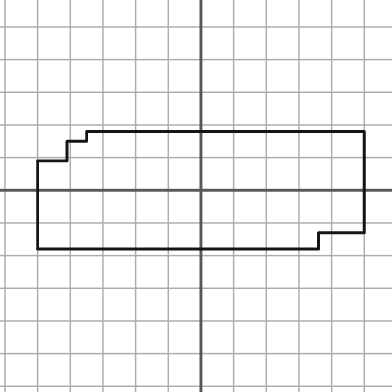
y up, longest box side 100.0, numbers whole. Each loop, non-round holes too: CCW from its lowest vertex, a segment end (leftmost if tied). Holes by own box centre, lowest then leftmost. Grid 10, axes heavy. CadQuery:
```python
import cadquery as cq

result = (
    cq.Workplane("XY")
    .moveTo(-50.0, -18.0)
    .lineTo(36.0, -18.0)
    .lineTo(36.0, -13.0)
    .lineTo(50.0, -13.0)
    .lineTo(50.0, 18.0)
    .lineTo(-35.0, 18.0)
    .lineTo(-35.0, 15.0)
    .lineTo(-41.0, 15.0)
    .lineTo(-41.0, 9.0)
    .lineTo(-50.0, 9.0)
    .close()
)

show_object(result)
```